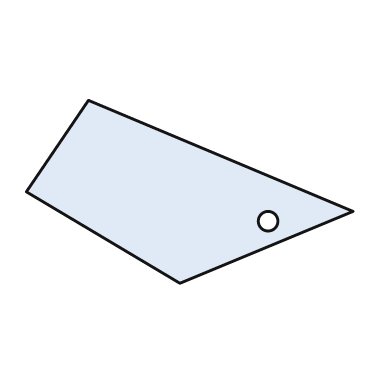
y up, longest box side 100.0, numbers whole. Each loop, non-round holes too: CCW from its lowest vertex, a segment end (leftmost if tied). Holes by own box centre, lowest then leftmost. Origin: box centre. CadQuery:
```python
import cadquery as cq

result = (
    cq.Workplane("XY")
    .moveTo(-3.0, -28.0)
    .lineTo(50.0, -6.0)
    .lineTo(-31.0, 28.0)
    .lineTo(-50.0, 0.0)
    .close()
    .moveTo(24.0, -9.0)
    .circle(3.0)
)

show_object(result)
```